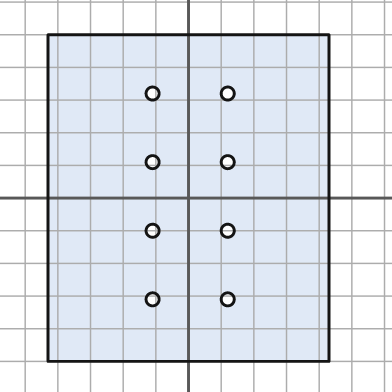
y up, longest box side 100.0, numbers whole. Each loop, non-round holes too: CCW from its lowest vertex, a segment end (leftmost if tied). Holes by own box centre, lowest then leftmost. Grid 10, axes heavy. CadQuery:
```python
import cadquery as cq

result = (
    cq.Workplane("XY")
    .moveTo(-43.0, -50.0)
    .lineTo(43.0, -50.0)
    .lineTo(43.0, 50.0)
    .lineTo(-43.0, 50.0)
    .close()
    .moveTo(-11.0, -31.0)
    .circle(2.0)
    .moveTo(12.0, -31.0)
    .circle(2.0)
    .moveTo(-11.0, -10.0)
    .circle(2.0)
    .moveTo(12.0, -10.0)
    .circle(2.0)
    .moveTo(-11.0, 11.0)
    .circle(2.0)
    .moveTo(12.0, 11.0)
    .circle(2.0)
    .moveTo(-11.0, 32.0)
    .circle(2.0)
    .moveTo(12.0, 32.0)
    .circle(2.0)
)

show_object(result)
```